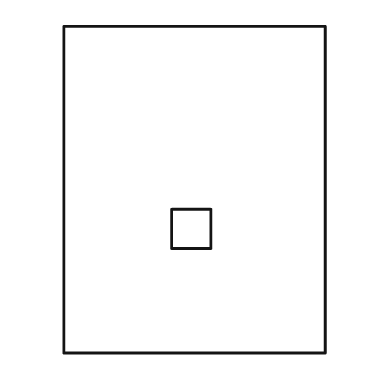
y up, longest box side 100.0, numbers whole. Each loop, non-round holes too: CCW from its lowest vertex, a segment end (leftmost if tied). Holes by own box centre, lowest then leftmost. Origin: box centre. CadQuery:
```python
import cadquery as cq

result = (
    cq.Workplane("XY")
    .moveTo(-40.0, -50.0)
    .lineTo(40.0, -50.0)
    .lineTo(40.0, 50.0)
    .lineTo(-40.0, 50.0)
    .close()
    .moveTo(-7.0, -18.0)
    .lineTo(5.0, -18.0)
    .lineTo(5.0, -6.0)
    .lineTo(-7.0, -6.0)
    .close()
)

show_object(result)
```